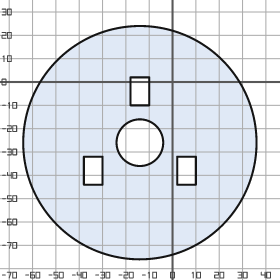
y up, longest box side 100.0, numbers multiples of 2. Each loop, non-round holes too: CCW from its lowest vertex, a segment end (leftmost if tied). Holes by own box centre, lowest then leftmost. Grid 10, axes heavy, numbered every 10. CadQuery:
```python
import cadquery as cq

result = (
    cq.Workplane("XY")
    .moveTo(-14.0, -26.0)
    .circle(50.0)
    .moveTo(-38.0, -44.0)
    .lineTo(-30.0, -44.0)
    .lineTo(-30.0, -32.0)
    .lineTo(-38.0, -32.0)
    .close()
    .moveTo(2.0, -44.0)
    .lineTo(10.0, -44.0)
    .lineTo(10.0, -32.0)
    .lineTo(2.0, -32.0)
    .close()
    .moveTo(-14.0, -26.0)
    .circle(10.0)
    .moveTo(-18.0, -10.0)
    .lineTo(-10.0, -10.0)
    .lineTo(-10.0, 2.0)
    .lineTo(-18.0, 2.0)
    .close()
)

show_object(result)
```